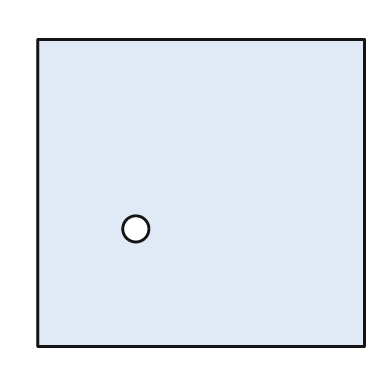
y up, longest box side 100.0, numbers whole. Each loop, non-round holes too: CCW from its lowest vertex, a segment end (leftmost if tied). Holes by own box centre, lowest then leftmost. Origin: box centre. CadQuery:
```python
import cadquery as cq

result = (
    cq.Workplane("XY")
    .moveTo(-50.0, -47.0)
    .lineTo(50.0, -47.0)
    .lineTo(50.0, 47.0)
    .lineTo(-50.0, 47.0)
    .close()
    .moveTo(-20.0, -11.0)
    .circle(4.0)
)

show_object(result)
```